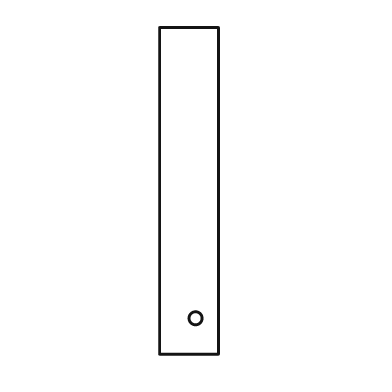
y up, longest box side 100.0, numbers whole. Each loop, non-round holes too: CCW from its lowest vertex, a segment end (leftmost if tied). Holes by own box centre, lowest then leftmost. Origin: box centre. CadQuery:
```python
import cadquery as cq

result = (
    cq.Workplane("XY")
    .moveTo(-9.0, -50.0)
    .lineTo(9.0, -50.0)
    .lineTo(9.0, 50.0)
    .lineTo(-9.0, 50.0)
    .close()
    .moveTo(2.0, -39.0)
    .circle(2.0)
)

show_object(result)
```